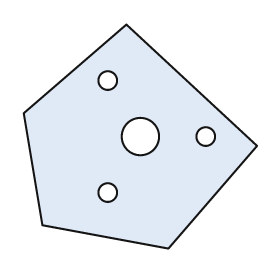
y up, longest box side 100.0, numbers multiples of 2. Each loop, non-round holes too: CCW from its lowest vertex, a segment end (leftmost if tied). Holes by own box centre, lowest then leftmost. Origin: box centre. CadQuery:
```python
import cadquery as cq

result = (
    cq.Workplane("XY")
    .moveTo(12.0, -48.0)
    .lineTo(50.0, -4.0)
    .lineTo(-6.0, 48.0)
    .lineTo(-50.0, 10.0)
    .lineTo(-42.0, -38.0)
    .close()
    .moveTo(-14.0, -24.0)
    .circle(4.0)
    .moveTo(0.0, 0.0)
    .circle(8.0)
    .moveTo(28.0, 0.0)
    .circle(4.0)
    .moveTo(-14.0, 24.0)
    .circle(4.0)
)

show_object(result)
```